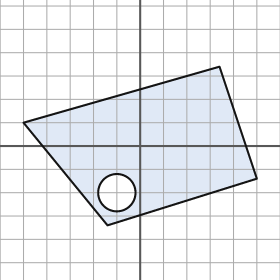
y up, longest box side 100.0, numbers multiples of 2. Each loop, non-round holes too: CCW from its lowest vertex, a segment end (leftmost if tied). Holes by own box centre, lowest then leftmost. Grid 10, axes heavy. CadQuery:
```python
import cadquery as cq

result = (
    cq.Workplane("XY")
    .moveTo(-14.0, -34.0)
    .lineTo(50.0, -14.0)
    .lineTo(34.0, 34.0)
    .lineTo(-50.0, 10.0)
    .close()
    .moveTo(-10.0, -20.0)
    .circle(8.0)
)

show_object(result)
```